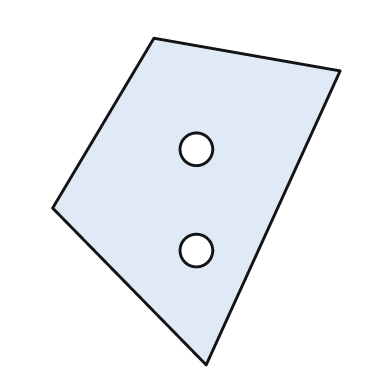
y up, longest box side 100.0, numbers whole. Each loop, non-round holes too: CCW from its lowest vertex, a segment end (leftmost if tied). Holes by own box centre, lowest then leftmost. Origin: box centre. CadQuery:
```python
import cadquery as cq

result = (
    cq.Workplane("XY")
    .moveTo(3.0, -50.0)
    .lineTo(44.0, 40.0)
    .lineTo(-13.0, 50.0)
    .lineTo(-44.0, -2.0)
    .close()
    .moveTo(0.0, -15.0)
    .circle(5.0)
    .moveTo(0.0, 16.0)
    .circle(5.0)
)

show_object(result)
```